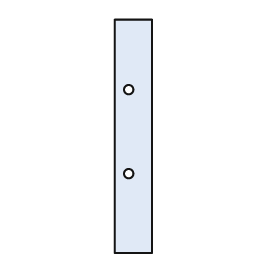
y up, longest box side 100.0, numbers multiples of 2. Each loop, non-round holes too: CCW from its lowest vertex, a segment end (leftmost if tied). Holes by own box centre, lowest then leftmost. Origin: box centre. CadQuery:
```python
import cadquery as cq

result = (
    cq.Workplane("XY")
    .moveTo(-8.0, -50.0)
    .lineTo(8.0, -50.0)
    .lineTo(8.0, 50.0)
    .lineTo(-8.0, 50.0)
    .close()
    .moveTo(-2.0, -16.0)
    .circle(2.0)
    .moveTo(-2.0, 20.0)
    .circle(2.0)
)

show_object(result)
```